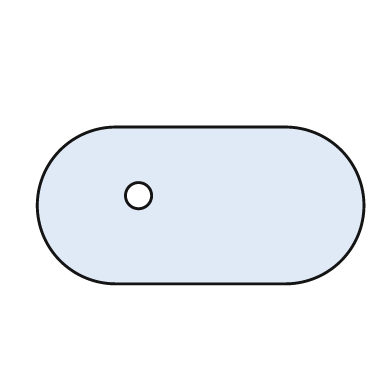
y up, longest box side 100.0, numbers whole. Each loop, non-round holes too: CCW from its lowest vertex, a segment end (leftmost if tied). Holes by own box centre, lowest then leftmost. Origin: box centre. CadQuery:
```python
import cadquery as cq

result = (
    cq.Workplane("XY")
    .moveTo(-26.0, -24.0)
    .lineTo(26.0, -24.0)
    .threePointArc((50.0, 0.0), (26.0, 24.0))
    .lineTo(-26.0, 24.0)
    .threePointArc((-50.0, 0.0), (-26.0, -24.0))
    .close()
    .moveTo(-19.0, 3.0)
    .circle(4.0)
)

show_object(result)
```